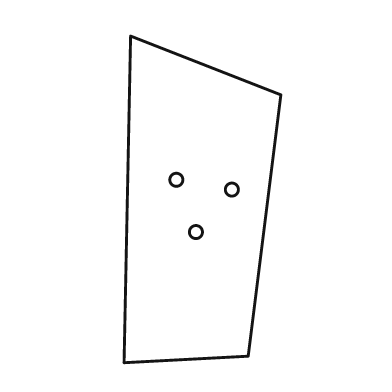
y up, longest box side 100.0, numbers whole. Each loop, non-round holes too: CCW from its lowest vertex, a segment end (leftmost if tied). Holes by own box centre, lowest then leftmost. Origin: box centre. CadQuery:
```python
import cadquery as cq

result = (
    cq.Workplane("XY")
    .moveTo(-24.0, -50.0)
    .lineTo(14.0, -48.0)
    .lineTo(24.0, 32.0)
    .lineTo(-22.0, 50.0)
    .close()
    .moveTo(-2.0, -10.0)
    .circle(2.0)
    .moveTo(9.0, 3.0)
    .circle(2.0)
    .moveTo(-8.0, 6.0)
    .circle(2.0)
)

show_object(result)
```